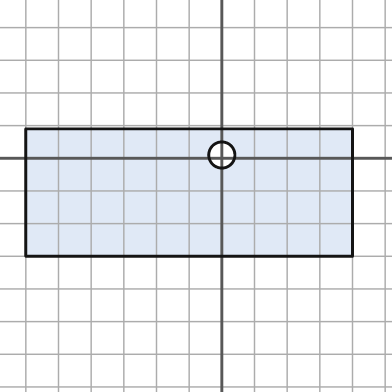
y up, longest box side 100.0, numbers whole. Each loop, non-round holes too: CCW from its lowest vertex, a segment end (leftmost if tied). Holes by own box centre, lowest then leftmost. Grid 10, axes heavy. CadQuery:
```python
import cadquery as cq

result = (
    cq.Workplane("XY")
    .moveTo(-60.0, -30.0)
    .lineTo(40.0, -30.0)
    .lineTo(40.0, 9.0)
    .lineTo(-60.0, 9.0)
    .close()
    .moveTo(0.0, 1.0)
    .circle(4.0)
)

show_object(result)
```